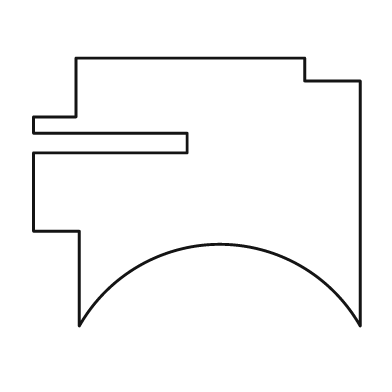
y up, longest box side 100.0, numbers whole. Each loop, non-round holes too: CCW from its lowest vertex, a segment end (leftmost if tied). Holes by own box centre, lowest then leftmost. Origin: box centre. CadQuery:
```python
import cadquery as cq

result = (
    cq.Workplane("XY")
    .moveTo(-36.0, -41.0)
    .threePointArc((7.0, -16.0), (50.0, -41.0))
    .lineTo(50.0, 34.0)
    .lineTo(33.0, 34.0)
    .lineTo(33.0, 41.0)
    .lineTo(-37.0, 41.0)
    .lineTo(-37.0, 23.0)
    .lineTo(-50.0, 23.0)
    .lineTo(-50.0, 18.0)
    .lineTo(-3.0, 18.0)
    .lineTo(-3.0, 12.0)
    .lineTo(-50.0, 12.0)
    .lineTo(-50.0, -12.0)
    .lineTo(-36.0, -12.0)
    .close()
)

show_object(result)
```